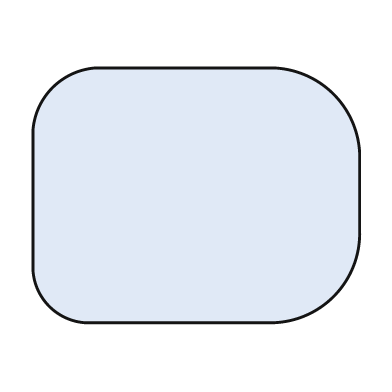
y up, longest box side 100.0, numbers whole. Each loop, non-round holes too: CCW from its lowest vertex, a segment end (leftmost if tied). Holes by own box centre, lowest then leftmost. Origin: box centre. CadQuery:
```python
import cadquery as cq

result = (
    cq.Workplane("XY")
    .moveTo(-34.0, -39.0)
    .lineTo(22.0, -39.0)
    .threePointArc((42.0, -31.0), (50.0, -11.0))
    .lineTo(50.0, 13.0)
    .threePointArc((42.0, 31.0), (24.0, 39.0))
    .lineTo(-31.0, 39.0)
    .threePointArc((-44.0, 33.0), (-50.0, 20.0))
    .lineTo(-50.0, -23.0)
    .threePointArc((-45.0, -34.0), (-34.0, -39.0))
    .close()
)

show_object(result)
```